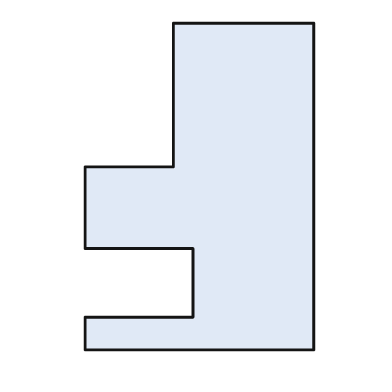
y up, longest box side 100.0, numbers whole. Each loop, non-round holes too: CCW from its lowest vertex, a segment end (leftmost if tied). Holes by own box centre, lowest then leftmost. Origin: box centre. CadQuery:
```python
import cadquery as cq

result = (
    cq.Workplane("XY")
    .moveTo(-35.0, -50.0)
    .lineTo(35.0, -50.0)
    .lineTo(35.0, 50.0)
    .lineTo(-8.0, 50.0)
    .lineTo(-8.0, 6.0)
    .lineTo(-35.0, 6.0)
    .lineTo(-35.0, -19.0)
    .lineTo(-2.0, -19.0)
    .lineTo(-2.0, -40.0)
    .lineTo(-35.0, -40.0)
    .close()
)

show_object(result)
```